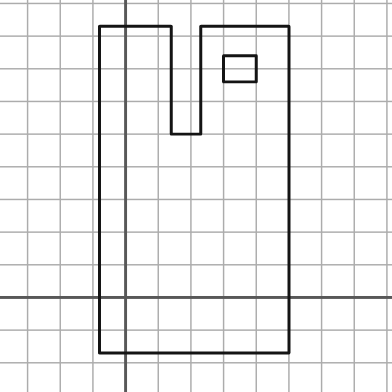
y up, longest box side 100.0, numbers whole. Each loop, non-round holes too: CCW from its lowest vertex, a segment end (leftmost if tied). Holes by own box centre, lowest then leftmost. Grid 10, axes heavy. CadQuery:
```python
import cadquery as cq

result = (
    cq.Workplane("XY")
    .moveTo(-8.0, -17.0)
    .lineTo(50.0, -17.0)
    .lineTo(50.0, 83.0)
    .lineTo(23.0, 83.0)
    .lineTo(23.0, 50.0)
    .lineTo(14.0, 50.0)
    .lineTo(14.0, 83.0)
    .lineTo(-8.0, 83.0)
    .close()
    .moveTo(30.0, 66.0)
    .lineTo(40.0, 66.0)
    .lineTo(40.0, 74.0)
    .lineTo(30.0, 74.0)
    .close()
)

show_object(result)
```